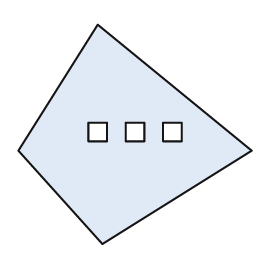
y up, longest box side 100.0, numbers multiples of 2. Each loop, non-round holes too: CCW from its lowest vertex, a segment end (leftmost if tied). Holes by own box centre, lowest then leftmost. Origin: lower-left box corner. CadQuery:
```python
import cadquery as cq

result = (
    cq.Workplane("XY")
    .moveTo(36.0, 0.0)
    .lineTo(100.0, 40.0)
    .lineTo(34.0, 94.0)
    .lineTo(0.0, 40.0)
    .close()
    .moveTo(30.0, 44.0)
    .lineTo(38.0, 44.0)
    .lineTo(38.0, 52.0)
    .lineTo(30.0, 52.0)
    .close()
    .moveTo(46.0, 44.0)
    .lineTo(54.0, 44.0)
    .lineTo(54.0, 52.0)
    .lineTo(46.0, 52.0)
    .close()
    .moveTo(62.0, 44.0)
    .lineTo(70.0, 44.0)
    .lineTo(70.0, 52.0)
    .lineTo(62.0, 52.0)
    .close()
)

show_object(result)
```